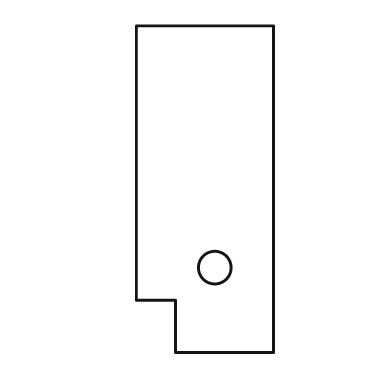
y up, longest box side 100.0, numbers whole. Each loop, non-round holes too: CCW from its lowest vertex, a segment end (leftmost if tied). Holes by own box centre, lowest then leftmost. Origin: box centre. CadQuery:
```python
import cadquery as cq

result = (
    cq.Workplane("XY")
    .moveTo(-9.0, -50.0)
    .lineTo(21.0, -50.0)
    .lineTo(21.0, 50.0)
    .lineTo(-21.0, 50.0)
    .lineTo(-21.0, -34.0)
    .lineTo(-9.0, -34.0)
    .close()
    .moveTo(3.0, -24.0)
    .circle(5.0)
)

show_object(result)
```